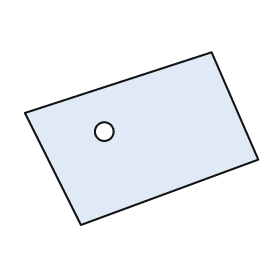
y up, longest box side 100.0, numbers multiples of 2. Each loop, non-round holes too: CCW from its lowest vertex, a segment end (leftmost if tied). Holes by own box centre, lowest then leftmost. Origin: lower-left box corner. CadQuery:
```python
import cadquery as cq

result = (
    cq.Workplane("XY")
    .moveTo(24.0, 0.0)
    .lineTo(100.0, 28.0)
    .lineTo(80.0, 74.0)
    .lineTo(0.0, 48.0)
    .close()
    .moveTo(34.0, 40.0)
    .circle(4.0)
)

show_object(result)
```